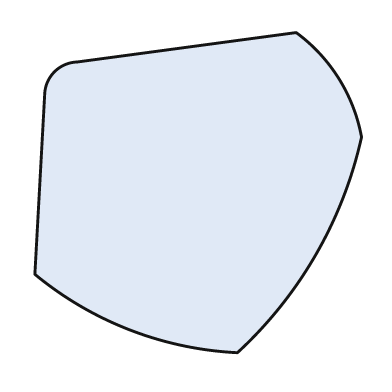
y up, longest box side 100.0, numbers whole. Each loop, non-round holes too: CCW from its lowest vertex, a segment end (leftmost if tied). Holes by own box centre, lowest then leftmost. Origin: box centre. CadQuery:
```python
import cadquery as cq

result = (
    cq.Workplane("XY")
    .moveTo(12.0, -49.0)
    .threePointArc((36.0, -19.0), (50.0, 17.0))
    .threePointArc((43.0, 35.0), (30.0, 49.0))
    .lineTo(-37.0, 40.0)
    .threePointArc((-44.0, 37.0), (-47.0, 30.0))
    .lineTo(-50.0, -25.0)
    .threePointArc((-21.0, -42.0), (12.0, -49.0))
    .close()
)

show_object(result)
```